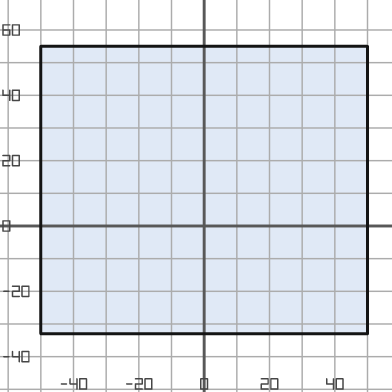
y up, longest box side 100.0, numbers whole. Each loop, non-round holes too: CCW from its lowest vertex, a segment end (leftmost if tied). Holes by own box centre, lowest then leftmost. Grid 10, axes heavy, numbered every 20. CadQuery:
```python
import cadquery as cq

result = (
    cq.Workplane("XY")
    .moveTo(-50.0, -33.0)
    .lineTo(50.0, -33.0)
    .lineTo(50.0, 55.0)
    .lineTo(-50.0, 55.0)
    .close()
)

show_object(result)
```